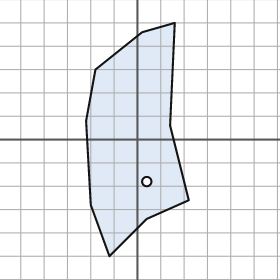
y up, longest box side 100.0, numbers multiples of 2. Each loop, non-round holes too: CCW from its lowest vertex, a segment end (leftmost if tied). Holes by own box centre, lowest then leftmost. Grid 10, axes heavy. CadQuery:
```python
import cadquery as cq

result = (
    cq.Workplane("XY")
    .moveTo(-12.0, -50.0)
    .lineTo(4.0, -34.0)
    .lineTo(22.0, -26.0)
    .lineTo(14.0, 6.0)
    .lineTo(16.0, 50.0)
    .lineTo(2.0, 46.0)
    .lineTo(-18.0, 30.0)
    .lineTo(-22.0, 8.0)
    .lineTo(-20.0, -28.0)
    .close()
    .moveTo(4.0, -18.0)
    .circle(2.0)
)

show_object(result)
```